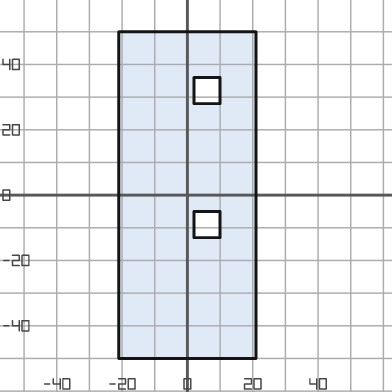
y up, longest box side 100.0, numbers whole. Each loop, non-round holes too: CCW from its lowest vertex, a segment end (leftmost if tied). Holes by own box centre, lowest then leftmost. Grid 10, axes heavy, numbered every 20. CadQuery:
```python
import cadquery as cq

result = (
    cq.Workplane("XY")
    .moveTo(-21.0, -50.0)
    .lineTo(21.0, -50.0)
    .lineTo(21.0, 50.0)
    .lineTo(-21.0, 50.0)
    .close()
    .moveTo(2.0, -13.0)
    .lineTo(10.0, -13.0)
    .lineTo(10.0, -5.0)
    .lineTo(2.0, -5.0)
    .close()
    .moveTo(2.0, 28.0)
    .lineTo(10.0, 28.0)
    .lineTo(10.0, 36.0)
    .lineTo(2.0, 36.0)
    .close()
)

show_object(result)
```